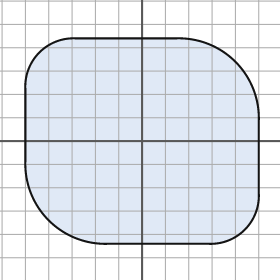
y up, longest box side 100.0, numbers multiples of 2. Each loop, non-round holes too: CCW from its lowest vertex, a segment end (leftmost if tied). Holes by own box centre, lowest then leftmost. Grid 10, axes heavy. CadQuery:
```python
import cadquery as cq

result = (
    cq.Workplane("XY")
    .moveTo(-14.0, -44.0)
    .lineTo(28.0, -44.0)
    .threePointArc((44.0, -38.0), (50.0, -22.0))
    .lineTo(50.0, 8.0)
    .threePointArc((40.0, 34.0), (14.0, 44.0))
    .lineTo(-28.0, 44.0)
    .threePointArc((-44.0, 38.0), (-50.0, 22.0))
    .lineTo(-50.0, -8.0)
    .threePointArc((-40.0, -34.0), (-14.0, -44.0))
    .close()
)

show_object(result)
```